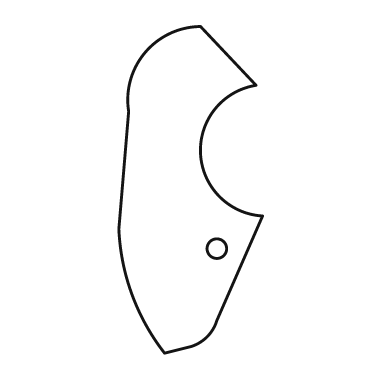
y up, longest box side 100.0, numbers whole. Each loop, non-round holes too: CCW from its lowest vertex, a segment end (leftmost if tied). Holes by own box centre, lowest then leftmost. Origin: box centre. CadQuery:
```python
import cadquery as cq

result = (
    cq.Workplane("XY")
    .moveTo(-8.0, -50.0)
    .lineTo(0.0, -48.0)
    .threePointArc((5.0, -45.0), (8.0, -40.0))
    .lineTo(22.0, -8.0)
    .threePointArc((3.0, 11.0), (20.0, 32.0))
    .lineTo(3.0, 50.0)
    .threePointArc((-14.0, 42.0), (-19.0, 24.0))
    .lineTo(-22.0, -12.0)
    .threePointArc((-18.0, -32.0), (-8.0, -50.0))
    .close()
    .moveTo(8.0, -18.0)
    .circle(3.0)
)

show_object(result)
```